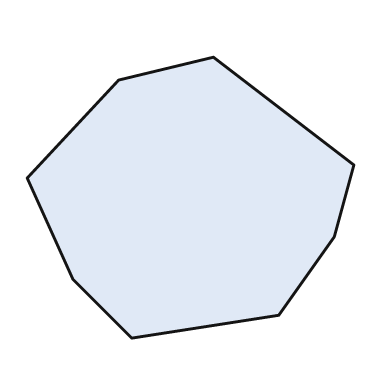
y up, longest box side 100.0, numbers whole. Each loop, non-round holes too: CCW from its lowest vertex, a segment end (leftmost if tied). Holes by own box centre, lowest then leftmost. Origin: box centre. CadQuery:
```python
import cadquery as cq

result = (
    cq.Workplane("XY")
    .moveTo(-18.0, -43.0)
    .lineTo(27.0, -36.0)
    .lineTo(44.0, -12.0)
    .lineTo(50.0, 10.0)
    .lineTo(7.0, 43.0)
    .lineTo(-22.0, 36.0)
    .lineTo(-50.0, 6.0)
    .lineTo(-36.0, -25.0)
    .close()
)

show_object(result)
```